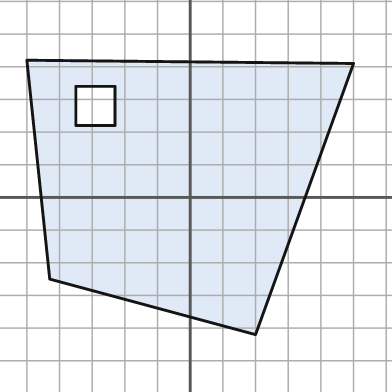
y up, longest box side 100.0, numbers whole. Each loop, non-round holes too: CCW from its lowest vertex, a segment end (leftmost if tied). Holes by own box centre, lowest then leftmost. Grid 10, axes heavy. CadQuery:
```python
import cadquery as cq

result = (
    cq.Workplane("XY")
    .moveTo(20.0, -42.0)
    .lineTo(50.0, 41.0)
    .lineTo(-50.0, 42.0)
    .lineTo(-43.0, -25.0)
    .close()
    .moveTo(-35.0, 22.0)
    .lineTo(-23.0, 22.0)
    .lineTo(-23.0, 34.0)
    .lineTo(-35.0, 34.0)
    .close()
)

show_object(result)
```